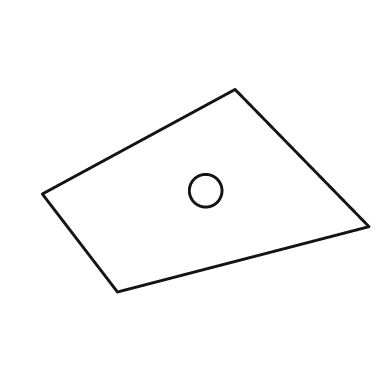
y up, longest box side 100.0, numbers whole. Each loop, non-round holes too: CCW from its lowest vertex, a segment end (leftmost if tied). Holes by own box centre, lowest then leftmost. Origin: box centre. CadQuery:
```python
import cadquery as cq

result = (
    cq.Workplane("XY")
    .moveTo(-27.0, -31.0)
    .lineTo(50.0, -11.0)
    .lineTo(9.0, 31.0)
    .lineTo(-50.0, -1.0)
    .close()
    .moveTo(0.0, 0.0)
    .circle(5.0)
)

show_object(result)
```